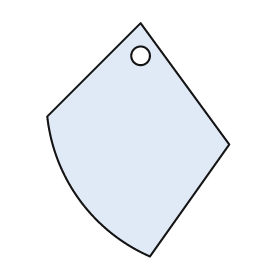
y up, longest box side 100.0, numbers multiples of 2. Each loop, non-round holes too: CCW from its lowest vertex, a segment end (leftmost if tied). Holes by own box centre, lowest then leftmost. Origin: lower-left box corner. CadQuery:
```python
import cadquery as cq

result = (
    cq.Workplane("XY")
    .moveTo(44.0, 0.0)
    .lineTo(78.0, 48.0)
    .lineTo(40.0, 100.0)
    .lineTo(0.0, 60.0)
    .threePointArc((14.0, 24.0), (44.0, 0.0))
    .close()
    .moveTo(40.0, 86.0)
    .circle(4.0)
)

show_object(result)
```